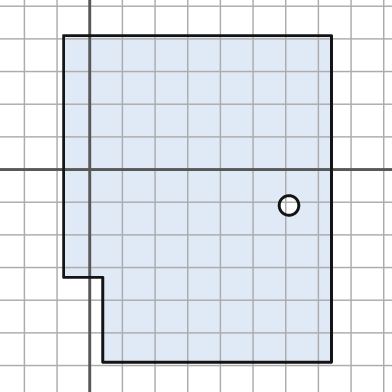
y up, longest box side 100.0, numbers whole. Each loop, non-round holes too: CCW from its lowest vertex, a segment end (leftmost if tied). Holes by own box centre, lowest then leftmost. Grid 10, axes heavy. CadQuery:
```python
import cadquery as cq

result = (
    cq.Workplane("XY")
    .moveTo(4.0, -59.0)
    .lineTo(74.0, -59.0)
    .lineTo(74.0, 41.0)
    .lineTo(-8.0, 41.0)
    .lineTo(-8.0, -33.0)
    .lineTo(4.0, -33.0)
    .close()
    .moveTo(61.0, -11.0)
    .circle(3.0)
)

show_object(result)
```